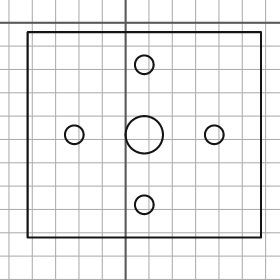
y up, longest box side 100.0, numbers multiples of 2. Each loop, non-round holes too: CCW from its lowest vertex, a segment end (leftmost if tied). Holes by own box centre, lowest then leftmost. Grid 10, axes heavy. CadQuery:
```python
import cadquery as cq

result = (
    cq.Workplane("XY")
    .moveTo(-42.0, -92.0)
    .lineTo(58.0, -92.0)
    .lineTo(58.0, -4.0)
    .lineTo(-42.0, -4.0)
    .close()
    .moveTo(8.0, -78.0)
    .circle(4.0)
    .moveTo(-22.0, -48.0)
    .circle(4.0)
    .moveTo(8.0, -48.0)
    .circle(8.0)
    .moveTo(38.0, -48.0)
    .circle(4.0)
    .moveTo(8.0, -18.0)
    .circle(4.0)
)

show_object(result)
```